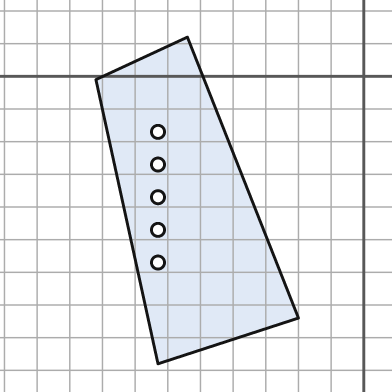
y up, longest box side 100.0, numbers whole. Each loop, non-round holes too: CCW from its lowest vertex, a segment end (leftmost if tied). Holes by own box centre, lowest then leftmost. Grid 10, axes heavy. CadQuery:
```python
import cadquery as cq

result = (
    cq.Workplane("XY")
    .moveTo(-63.0, -88.0)
    .lineTo(-20.0, -74.0)
    .lineTo(-54.0, 12.0)
    .lineTo(-82.0, -1.0)
    .close()
    .moveTo(-63.0, -57.0)
    .circle(2.0)
    .moveTo(-63.0, -47.0)
    .circle(2.0)
    .moveTo(-63.0, -37.0)
    .circle(2.0)
    .moveTo(-63.0, -27.0)
    .circle(2.0)
    .moveTo(-63.0, -17.0)
    .circle(2.0)
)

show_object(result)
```